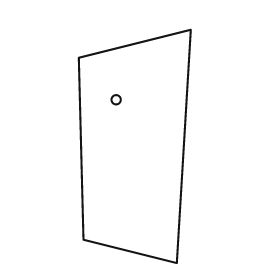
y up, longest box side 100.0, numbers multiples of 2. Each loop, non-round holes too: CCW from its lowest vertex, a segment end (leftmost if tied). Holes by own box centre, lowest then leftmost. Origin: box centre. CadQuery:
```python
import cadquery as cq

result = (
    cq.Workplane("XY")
    .moveTo(18.0, -50.0)
    .lineTo(24.0, 50.0)
    .lineTo(-24.0, 38.0)
    .lineTo(-22.0, -40.0)
    .close()
    .moveTo(-8.0, 20.0)
    .circle(2.0)
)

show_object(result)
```